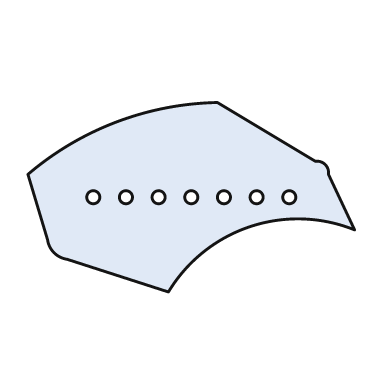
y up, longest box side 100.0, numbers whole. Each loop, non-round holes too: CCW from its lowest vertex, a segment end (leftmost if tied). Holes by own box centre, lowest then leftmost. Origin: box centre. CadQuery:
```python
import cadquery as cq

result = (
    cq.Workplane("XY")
    .moveTo(-7.0, -29.0)
    .threePointArc((18.0, -9.0), (50.0, -10.0))
    .lineTo(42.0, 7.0)
    .threePointArc((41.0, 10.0), (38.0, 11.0))
    .lineTo(8.0, 29.0)
    .threePointArc((-23.0, 23.0), (-50.0, 7.0))
    .lineTo(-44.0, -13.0)
    .threePointArc((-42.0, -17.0), (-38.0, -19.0))
    .close()
    .moveTo(-30.0, 0.0)
    .circle(2.0)
    .moveTo(-20.0, 0.0)
    .circle(2.0)
    .moveTo(-10.0, 0.0)
    .circle(2.0)
    .moveTo(0.0, 0.0)
    .circle(2.0)
    .moveTo(10.0, 0.0)
    .circle(2.0)
    .moveTo(20.0, 0.0)
    .circle(2.0)
    .moveTo(30.0, 0.0)
    .circle(2.0)
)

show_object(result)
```